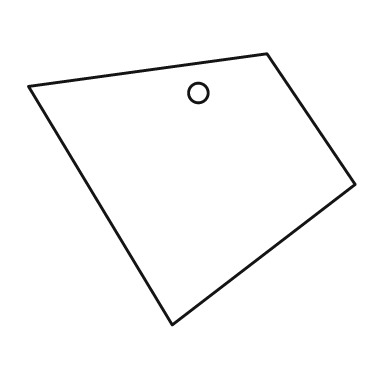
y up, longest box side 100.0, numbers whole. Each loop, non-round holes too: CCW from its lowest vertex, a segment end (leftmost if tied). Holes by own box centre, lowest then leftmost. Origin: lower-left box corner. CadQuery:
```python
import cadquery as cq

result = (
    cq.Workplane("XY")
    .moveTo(44.0, 0.0)
    .lineTo(100.0, 43.0)
    .lineTo(73.0, 83.0)
    .lineTo(0.0, 73.0)
    .close()
    .moveTo(52.0, 71.0)
    .circle(3.0)
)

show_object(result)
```